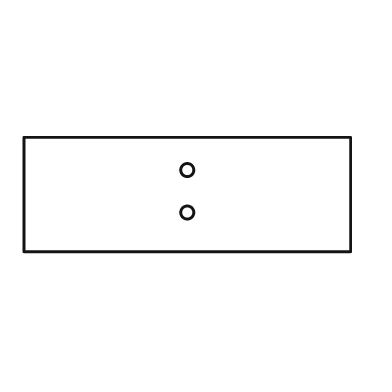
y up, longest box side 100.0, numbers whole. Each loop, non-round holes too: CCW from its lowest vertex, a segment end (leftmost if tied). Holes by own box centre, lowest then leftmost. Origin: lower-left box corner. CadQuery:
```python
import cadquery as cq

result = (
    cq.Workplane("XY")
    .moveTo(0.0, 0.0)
    .lineTo(100.0, 0.0)
    .lineTo(100.0, 35.0)
    .lineTo(0.0, 35.0)
    .close()
    .moveTo(50.0, 12.0)
    .circle(2.0)
    .moveTo(50.0, 25.0)
    .circle(2.0)
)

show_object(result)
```